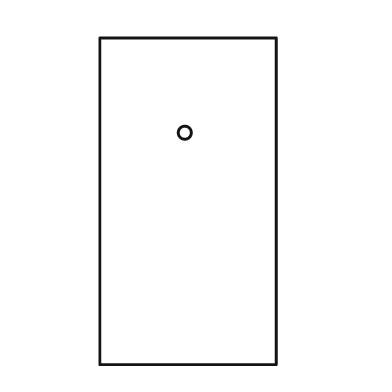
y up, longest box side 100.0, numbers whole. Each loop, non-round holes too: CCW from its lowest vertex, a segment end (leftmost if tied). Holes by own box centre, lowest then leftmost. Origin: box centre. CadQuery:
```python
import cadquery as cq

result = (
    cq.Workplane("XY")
    .moveTo(-27.0, -50.0)
    .lineTo(27.0, -50.0)
    .lineTo(27.0, 50.0)
    .lineTo(-27.0, 50.0)
    .close()
    .moveTo(-1.0, 21.0)
    .circle(2.0)
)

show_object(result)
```